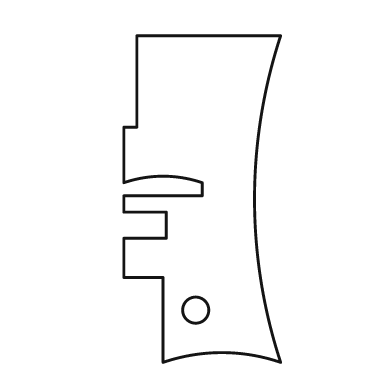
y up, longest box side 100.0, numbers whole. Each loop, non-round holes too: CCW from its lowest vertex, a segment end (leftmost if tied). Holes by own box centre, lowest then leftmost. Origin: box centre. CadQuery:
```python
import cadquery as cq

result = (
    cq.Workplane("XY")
    .moveTo(-12.0, -50.0)
    .threePointArc((6.0, -47.0), (24.0, -50.0))
    .threePointArc((16.0, 0.0), (24.0, 50.0))
    .lineTo(-20.0, 50.0)
    .lineTo(-20.0, 22.0)
    .lineTo(-24.0, 22.0)
    .lineTo(-24.0, 5.0)
    .threePointArc((-12.0, 7.0), (0.0, 5.0))
    .lineTo(0.0, 1.0)
    .lineTo(-24.0, 1.0)
    .lineTo(-24.0, -4.0)
    .lineTo(-11.0, -4.0)
    .lineTo(-11.0, -12.0)
    .lineTo(-24.0, -12.0)
    .lineTo(-24.0, -24.0)
    .lineTo(-12.0, -24.0)
    .close()
    .moveTo(-2.0, -34.0)
    .circle(4.0)
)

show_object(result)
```